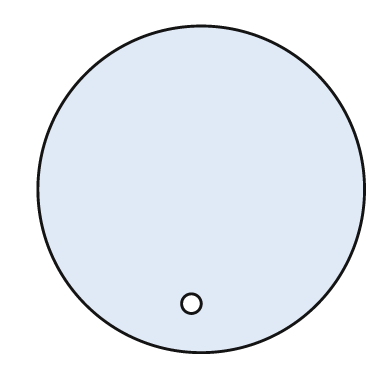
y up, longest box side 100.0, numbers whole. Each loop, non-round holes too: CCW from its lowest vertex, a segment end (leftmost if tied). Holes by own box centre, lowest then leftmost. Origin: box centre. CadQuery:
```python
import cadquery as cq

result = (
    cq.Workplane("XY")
    .moveTo(0.0, 0.0)
    .circle(50.0)
    .moveTo(-3.0, -35.0)
    .circle(3.0)
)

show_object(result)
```